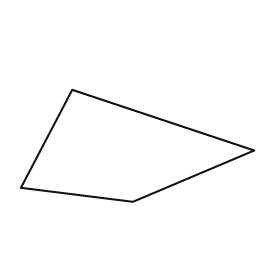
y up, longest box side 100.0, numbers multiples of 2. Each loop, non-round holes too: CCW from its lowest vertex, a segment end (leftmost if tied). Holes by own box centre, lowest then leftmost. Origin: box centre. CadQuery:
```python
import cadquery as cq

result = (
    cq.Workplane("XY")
    .moveTo(-2.0, -24.0)
    .lineTo(50.0, -2.0)
    .lineTo(-28.0, 24.0)
    .lineTo(-50.0, -18.0)
    .close()
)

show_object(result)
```